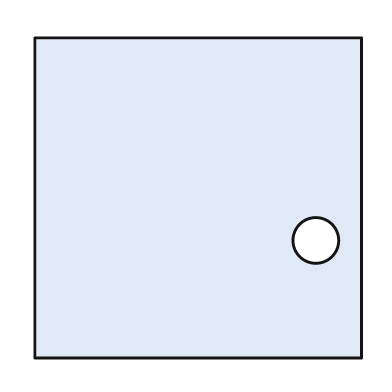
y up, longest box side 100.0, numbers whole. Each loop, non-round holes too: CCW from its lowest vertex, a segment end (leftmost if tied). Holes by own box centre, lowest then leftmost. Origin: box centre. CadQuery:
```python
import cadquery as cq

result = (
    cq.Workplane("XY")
    .moveTo(-50.0, -49.0)
    .lineTo(50.0, -49.0)
    .lineTo(50.0, 49.0)
    .lineTo(-50.0, 49.0)
    .close()
    .moveTo(36.0, -13.0)
    .circle(7.0)
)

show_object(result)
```